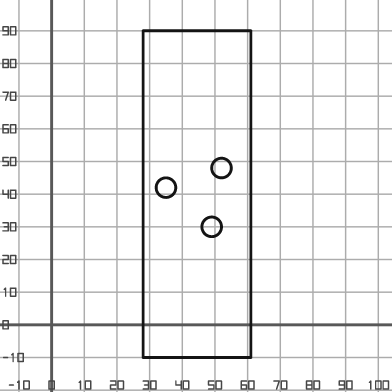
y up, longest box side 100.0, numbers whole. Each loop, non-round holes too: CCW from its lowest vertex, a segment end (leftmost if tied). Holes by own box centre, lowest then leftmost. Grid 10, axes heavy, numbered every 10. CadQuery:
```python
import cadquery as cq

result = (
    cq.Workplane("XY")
    .moveTo(28.0, -10.0)
    .lineTo(61.0, -10.0)
    .lineTo(61.0, 90.0)
    .lineTo(28.0, 90.0)
    .close()
    .moveTo(49.0, 30.0)
    .circle(3.0)
    .moveTo(35.0, 42.0)
    .circle(3.0)
    .moveTo(52.0, 48.0)
    .circle(3.0)
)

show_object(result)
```